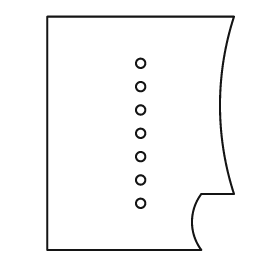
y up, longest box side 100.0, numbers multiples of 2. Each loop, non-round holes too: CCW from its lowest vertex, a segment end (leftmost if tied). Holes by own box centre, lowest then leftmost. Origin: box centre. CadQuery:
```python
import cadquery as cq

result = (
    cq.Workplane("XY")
    .moveTo(-40.0, -50.0)
    .lineTo(26.0, -50.0)
    .threePointArc((22.0, -38.0), (26.0, -26.0))
    .lineTo(40.0, -26.0)
    .threePointArc((34.0, 12.0), (40.0, 50.0))
    .lineTo(-40.0, 50.0)
    .close()
    .moveTo(0.0, -30.0)
    .circle(2.0)
    .moveTo(0.0, -20.0)
    .circle(2.0)
    .moveTo(0.0, -10.0)
    .circle(2.0)
    .moveTo(0.0, 0.0)
    .circle(2.0)
    .moveTo(0.0, 10.0)
    .circle(2.0)
    .moveTo(0.0, 20.0)
    .circle(2.0)
    .moveTo(0.0, 30.0)
    .circle(2.0)
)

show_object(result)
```